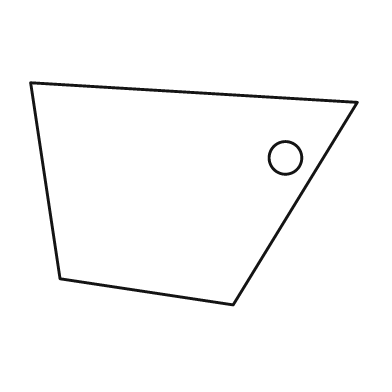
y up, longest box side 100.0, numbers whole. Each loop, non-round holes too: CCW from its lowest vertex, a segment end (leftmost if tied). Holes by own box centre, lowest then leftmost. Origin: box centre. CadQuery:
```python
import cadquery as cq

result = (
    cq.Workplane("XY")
    .moveTo(12.0, -34.0)
    .lineTo(50.0, 28.0)
    .lineTo(-50.0, 34.0)
    .lineTo(-41.0, -26.0)
    .close()
    .moveTo(28.0, 11.0)
    .circle(5.0)
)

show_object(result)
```